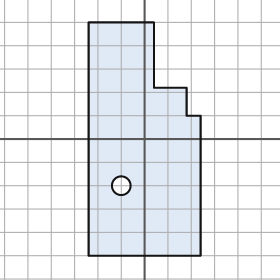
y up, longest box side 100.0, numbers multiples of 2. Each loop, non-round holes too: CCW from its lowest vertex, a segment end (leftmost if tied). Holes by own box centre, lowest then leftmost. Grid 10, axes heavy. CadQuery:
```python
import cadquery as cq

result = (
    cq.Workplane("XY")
    .moveTo(-24.0, -50.0)
    .lineTo(24.0, -50.0)
    .lineTo(24.0, 10.0)
    .lineTo(18.0, 10.0)
    .lineTo(18.0, 22.0)
    .lineTo(4.0, 22.0)
    .lineTo(4.0, 50.0)
    .lineTo(-24.0, 50.0)
    .close()
    .moveTo(-10.0, -20.0)
    .circle(4.0)
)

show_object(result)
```